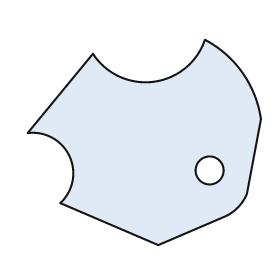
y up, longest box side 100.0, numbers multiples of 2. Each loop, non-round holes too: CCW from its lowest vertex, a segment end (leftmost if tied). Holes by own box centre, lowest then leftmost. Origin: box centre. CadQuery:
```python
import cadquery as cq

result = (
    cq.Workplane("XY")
    .moveTo(6.0, -44.0)
    .lineTo(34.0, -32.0)
    .threePointArc((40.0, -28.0), (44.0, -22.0))
    .lineTo(50.0, 10.0)
    .threePointArc((42.0, 30.0), (26.0, 44.0))
    .threePointArc((4.0, 26.0), (-22.0, 38.0))
    .lineTo(-50.0, 4.0)
    .threePointArc((-32.0, -6.0), (-36.0, -26.0))
    .close()
    .moveTo(28.0, -12.0)
    .circle(6.0)
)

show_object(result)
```